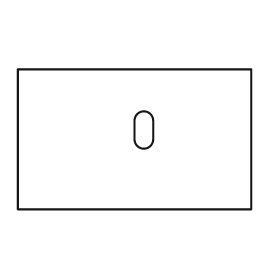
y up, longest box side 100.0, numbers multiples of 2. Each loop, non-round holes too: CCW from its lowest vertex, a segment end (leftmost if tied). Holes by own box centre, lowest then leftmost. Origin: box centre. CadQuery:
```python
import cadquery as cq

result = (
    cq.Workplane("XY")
    .moveTo(-50.0, -30.0)
    .lineTo(50.0, -30.0)
    .lineTo(50.0, 30.0)
    .lineTo(-50.0, 30.0)
    .close()
    .moveTo(0.0, 0.0)
    .threePointArc((4.0, -4.0), (8.0, 0.0))
    .lineTo(8.0, 8.0)
    .threePointArc((4.0, 12.0), (0.0, 8.0))
    .close()
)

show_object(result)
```